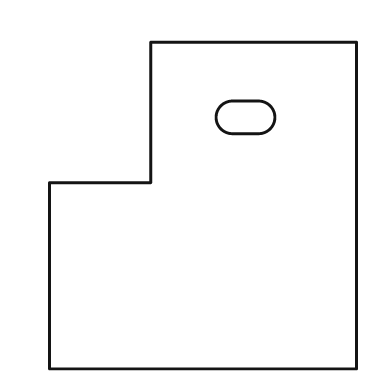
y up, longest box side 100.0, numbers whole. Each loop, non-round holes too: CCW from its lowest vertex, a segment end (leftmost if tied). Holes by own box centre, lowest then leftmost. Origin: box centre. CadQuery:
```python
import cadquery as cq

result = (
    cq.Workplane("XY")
    .moveTo(-47.0, -50.0)
    .lineTo(47.0, -50.0)
    .lineTo(47.0, 50.0)
    .lineTo(-16.0, 50.0)
    .lineTo(-16.0, 7.0)
    .lineTo(-47.0, 7.0)
    .close()
    .moveTo(9.0, 22.0)
    .lineTo(17.0, 22.0)
    .threePointArc((22.0, 27.0), (17.0, 32.0))
    .lineTo(9.0, 32.0)
    .threePointArc((4.0, 27.0), (9.0, 22.0))
    .close()
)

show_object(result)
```